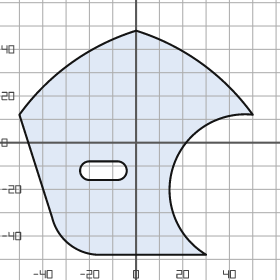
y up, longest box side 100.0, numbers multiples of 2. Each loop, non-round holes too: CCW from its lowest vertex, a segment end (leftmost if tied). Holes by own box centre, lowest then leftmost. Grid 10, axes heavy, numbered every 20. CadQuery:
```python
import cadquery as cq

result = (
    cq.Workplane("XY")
    .moveTo(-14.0, -48.0)
    .lineTo(30.0, -48.0)
    .threePointArc((16.0, -10.0), (50.0, 12.0))
    .threePointArc((28.0, 34.0), (0.0, 48.0))
    .threePointArc((-28.0, 34.0), (-50.0, 12.0))
    .lineTo(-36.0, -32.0)
    .threePointArc((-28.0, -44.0), (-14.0, -48.0))
    .close()
    .moveTo(-20.0, -16.0)
    .lineTo(-8.0, -16.0)
    .threePointArc((-4.0, -12.0), (-8.0, -8.0))
    .lineTo(-20.0, -8.0)
    .threePointArc((-24.0, -12.0), (-20.0, -16.0))
    .close()
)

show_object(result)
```